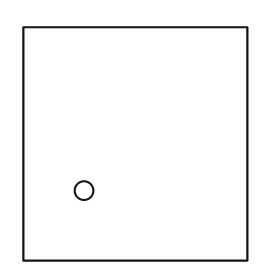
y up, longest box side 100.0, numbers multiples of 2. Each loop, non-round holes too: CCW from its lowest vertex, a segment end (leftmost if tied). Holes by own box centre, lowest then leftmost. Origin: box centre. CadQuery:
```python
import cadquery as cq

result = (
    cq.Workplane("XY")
    .moveTo(-48.0, -50.0)
    .lineTo(48.0, -50.0)
    .lineTo(48.0, 50.0)
    .lineTo(-48.0, 50.0)
    .close()
    .moveTo(-22.0, -20.0)
    .circle(4.0)
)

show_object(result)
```